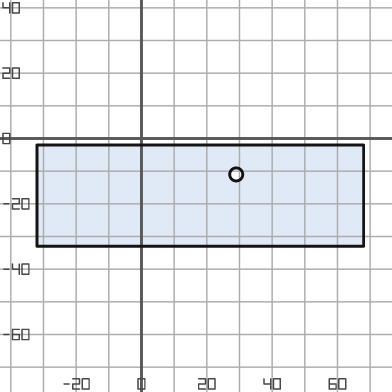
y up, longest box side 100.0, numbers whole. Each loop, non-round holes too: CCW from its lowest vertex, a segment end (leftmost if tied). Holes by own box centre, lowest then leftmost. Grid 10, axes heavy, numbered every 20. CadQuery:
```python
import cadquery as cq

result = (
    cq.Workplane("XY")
    .moveTo(-32.0, -33.0)
    .lineTo(68.0, -33.0)
    .lineTo(68.0, -2.0)
    .lineTo(-32.0, -2.0)
    .close()
    .moveTo(29.0, -11.0)
    .circle(2.0)
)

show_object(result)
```